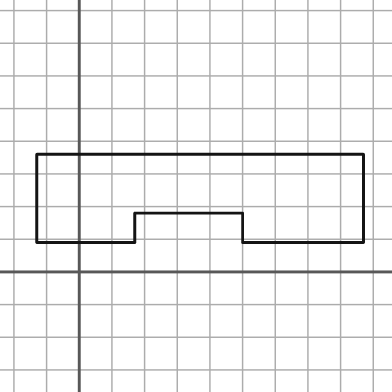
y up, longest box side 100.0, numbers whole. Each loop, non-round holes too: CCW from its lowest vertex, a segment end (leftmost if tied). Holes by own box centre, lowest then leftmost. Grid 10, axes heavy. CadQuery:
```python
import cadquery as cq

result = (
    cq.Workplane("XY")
    .moveTo(-13.0, 9.0)
    .lineTo(17.0, 9.0)
    .lineTo(17.0, 18.0)
    .lineTo(50.0, 18.0)
    .lineTo(50.0, 9.0)
    .lineTo(87.0, 9.0)
    .lineTo(87.0, 36.0)
    .lineTo(-13.0, 36.0)
    .close()
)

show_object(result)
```